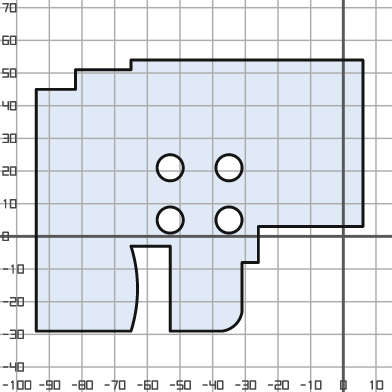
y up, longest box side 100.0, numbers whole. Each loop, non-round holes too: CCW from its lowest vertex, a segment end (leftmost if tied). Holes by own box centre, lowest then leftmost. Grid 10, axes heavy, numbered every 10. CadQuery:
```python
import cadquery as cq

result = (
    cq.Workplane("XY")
    .moveTo(-94.0, -29.0)
    .lineTo(-65.0, -29.0)
    .threePointArc((-63.0, -16.0), (-65.0, -3.0))
    .lineTo(-53.0, -3.0)
    .lineTo(-53.0, -29.0)
    .lineTo(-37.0, -29.0)
    .threePointArc((-33.0, -27.0), (-31.0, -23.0))
    .lineTo(-31.0, -8.0)
    .lineTo(-26.0, -8.0)
    .lineTo(-26.0, 3.0)
    .lineTo(6.0, 3.0)
    .lineTo(6.0, 54.0)
    .lineTo(-65.0, 54.0)
    .lineTo(-65.0, 51.0)
    .lineTo(-82.0, 51.0)
    .lineTo(-82.0, 45.0)
    .lineTo(-94.0, 45.0)
    .close()
    .moveTo(-53.0, 5.0)
    .circle(4.0)
    .moveTo(-35.0, 5.0)
    .circle(4.0)
    .moveTo(-53.0, 21.0)
    .circle(4.0)
    .moveTo(-35.0, 21.0)
    .circle(4.0)
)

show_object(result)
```